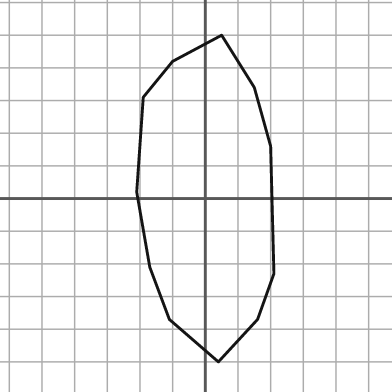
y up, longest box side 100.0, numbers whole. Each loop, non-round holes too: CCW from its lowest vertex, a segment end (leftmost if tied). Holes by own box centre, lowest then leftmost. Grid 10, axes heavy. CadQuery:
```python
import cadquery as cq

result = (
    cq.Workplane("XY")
    .moveTo(4.0, -50.0)
    .lineTo(16.0, -37.0)
    .lineTo(21.0, -23.0)
    .lineTo(20.0, 16.0)
    .lineTo(15.0, 34.0)
    .lineTo(5.0, 50.0)
    .lineTo(-10.0, 42.0)
    .lineTo(-19.0, 31.0)
    .lineTo(-21.0, 2.0)
    .lineTo(-17.0, -21.0)
    .lineTo(-11.0, -37.0)
    .close()
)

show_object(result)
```